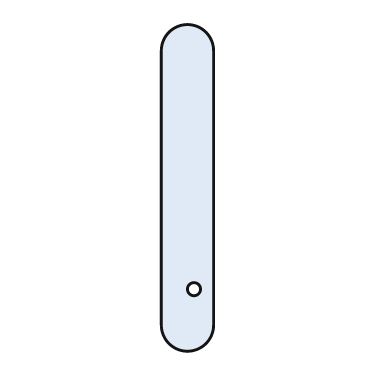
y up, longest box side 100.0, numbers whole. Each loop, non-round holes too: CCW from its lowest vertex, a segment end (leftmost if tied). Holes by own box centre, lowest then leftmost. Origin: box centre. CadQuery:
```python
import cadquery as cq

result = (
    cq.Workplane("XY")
    .moveTo(-8.0, -42.0)
    .threePointArc((0.0, -50.0), (8.0, -42.0))
    .lineTo(8.0, 42.0)
    .threePointArc((0.0, 50.0), (-8.0, 42.0))
    .close()
    .moveTo(2.0, -31.0)
    .circle(2.0)
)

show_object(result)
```